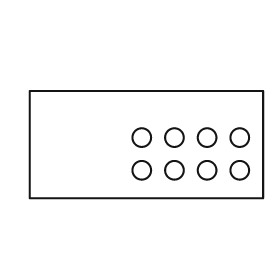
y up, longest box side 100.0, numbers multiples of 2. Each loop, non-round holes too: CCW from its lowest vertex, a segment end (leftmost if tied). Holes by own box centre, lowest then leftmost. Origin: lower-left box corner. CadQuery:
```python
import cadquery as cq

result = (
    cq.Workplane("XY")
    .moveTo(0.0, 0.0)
    .lineTo(100.0, 0.0)
    .lineTo(100.0, 46.0)
    .lineTo(0.0, 46.0)
    .close()
    .moveTo(48.0, 12.0)
    .circle(4.0)
    .moveTo(62.0, 12.0)
    .circle(4.0)
    .moveTo(76.0, 12.0)
    .circle(4.0)
    .moveTo(90.0, 12.0)
    .circle(4.0)
    .moveTo(48.0, 26.0)
    .circle(4.0)
    .moveTo(62.0, 26.0)
    .circle(4.0)
    .moveTo(76.0, 26.0)
    .circle(4.0)
    .moveTo(90.0, 26.0)
    .circle(4.0)
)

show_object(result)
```